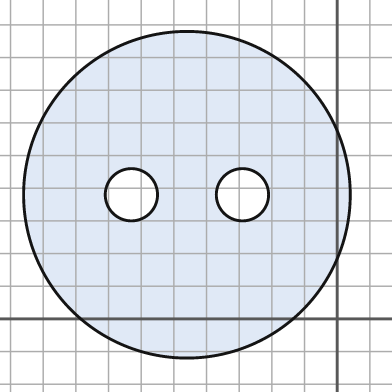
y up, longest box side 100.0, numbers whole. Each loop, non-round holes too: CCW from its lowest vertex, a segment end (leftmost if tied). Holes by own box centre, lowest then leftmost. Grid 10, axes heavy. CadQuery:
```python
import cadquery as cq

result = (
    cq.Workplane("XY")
    .moveTo(-46.0, 38.0)
    .circle(50.0)
    .moveTo(-63.0, 38.0)
    .circle(8.0)
    .moveTo(-29.0, 38.0)
    .circle(8.0)
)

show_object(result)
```